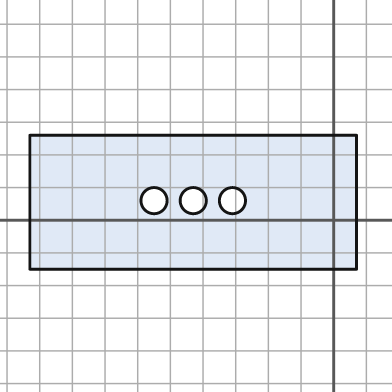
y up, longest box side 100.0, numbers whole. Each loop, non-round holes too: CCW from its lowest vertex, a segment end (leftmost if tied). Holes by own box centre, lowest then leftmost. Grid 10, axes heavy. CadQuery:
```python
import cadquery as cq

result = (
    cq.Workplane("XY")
    .moveTo(-93.0, -15.0)
    .lineTo(7.0, -15.0)
    .lineTo(7.0, 26.0)
    .lineTo(-93.0, 26.0)
    .close()
    .moveTo(-55.0, 6.0)
    .circle(4.0)
    .moveTo(-43.0, 6.0)
    .circle(4.0)
    .moveTo(-31.0, 6.0)
    .circle(4.0)
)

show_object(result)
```